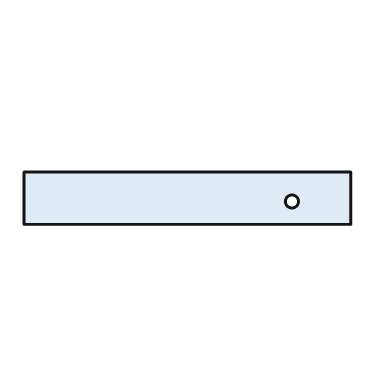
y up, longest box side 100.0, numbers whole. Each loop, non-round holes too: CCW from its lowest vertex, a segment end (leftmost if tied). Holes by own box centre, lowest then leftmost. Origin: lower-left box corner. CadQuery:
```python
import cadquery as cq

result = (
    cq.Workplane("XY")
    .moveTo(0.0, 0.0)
    .lineTo(100.0, 0.0)
    .lineTo(100.0, 16.0)
    .lineTo(0.0, 16.0)
    .close()
    .moveTo(82.0, 7.0)
    .circle(2.0)
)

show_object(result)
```